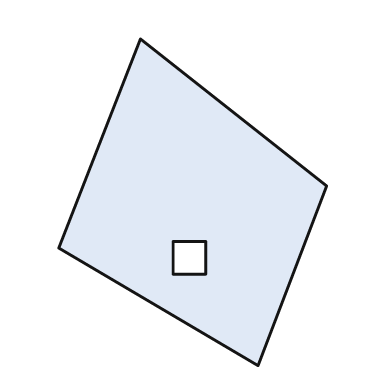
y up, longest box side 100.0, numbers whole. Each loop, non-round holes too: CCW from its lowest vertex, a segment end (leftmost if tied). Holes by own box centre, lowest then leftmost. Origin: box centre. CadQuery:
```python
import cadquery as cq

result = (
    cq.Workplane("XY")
    .moveTo(20.0, -50.0)
    .lineTo(41.0, 5.0)
    .lineTo(-16.0, 50.0)
    .lineTo(-41.0, -14.0)
    .close()
    .moveTo(-6.0, -22.0)
    .lineTo(4.0, -22.0)
    .lineTo(4.0, -12.0)
    .lineTo(-6.0, -12.0)
    .close()
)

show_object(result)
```